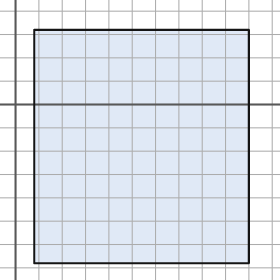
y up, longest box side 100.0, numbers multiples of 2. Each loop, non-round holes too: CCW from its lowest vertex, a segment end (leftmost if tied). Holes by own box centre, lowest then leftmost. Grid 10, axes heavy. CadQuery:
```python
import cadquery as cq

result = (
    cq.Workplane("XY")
    .moveTo(8.0, -68.0)
    .lineTo(100.0, -68.0)
    .lineTo(100.0, 32.0)
    .lineTo(8.0, 32.0)
    .close()
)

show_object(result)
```